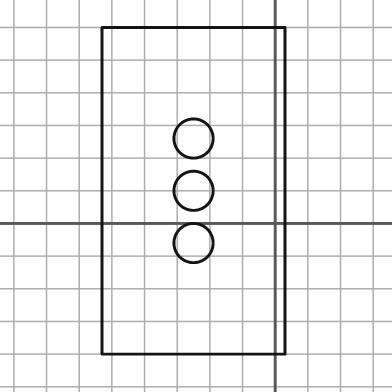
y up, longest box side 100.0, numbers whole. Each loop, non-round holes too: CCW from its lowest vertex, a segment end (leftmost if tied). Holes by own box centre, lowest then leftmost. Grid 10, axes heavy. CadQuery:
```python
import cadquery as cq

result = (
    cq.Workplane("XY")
    .moveTo(-53.0, -40.0)
    .lineTo(3.0, -40.0)
    .lineTo(3.0, 60.0)
    .lineTo(-53.0, 60.0)
    .close()
    .moveTo(-25.0, -6.0)
    .circle(6.0)
    .moveTo(-25.0, 10.0)
    .circle(6.0)
    .moveTo(-25.0, 26.0)
    .circle(6.0)
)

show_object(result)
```